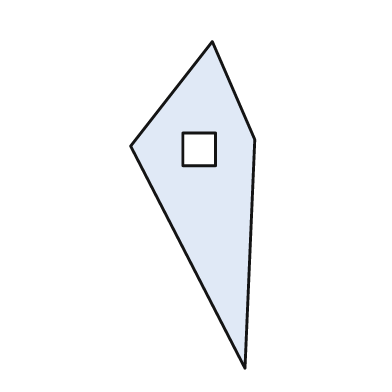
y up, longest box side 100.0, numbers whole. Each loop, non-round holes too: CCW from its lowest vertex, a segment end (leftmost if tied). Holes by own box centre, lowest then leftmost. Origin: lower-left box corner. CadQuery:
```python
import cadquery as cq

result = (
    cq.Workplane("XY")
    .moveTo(35.0, 0.0)
    .lineTo(38.0, 70.0)
    .lineTo(25.0, 100.0)
    .lineTo(0.0, 68.0)
    .close()
    .moveTo(16.0, 62.0)
    .lineTo(26.0, 62.0)
    .lineTo(26.0, 72.0)
    .lineTo(16.0, 72.0)
    .close()
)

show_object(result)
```